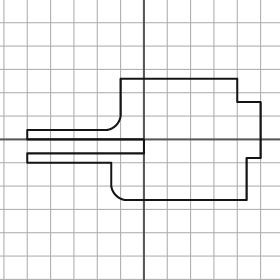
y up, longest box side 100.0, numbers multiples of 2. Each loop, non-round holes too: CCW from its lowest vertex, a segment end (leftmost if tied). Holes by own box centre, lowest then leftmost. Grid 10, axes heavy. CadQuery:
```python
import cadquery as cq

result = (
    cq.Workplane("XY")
    .moveTo(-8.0, -26.0)
    .lineTo(44.0, -26.0)
    .lineTo(44.0, -8.0)
    .lineTo(50.0, -8.0)
    .lineTo(50.0, 16.0)
    .lineTo(40.0, 16.0)
    .lineTo(40.0, 26.0)
    .lineTo(-10.0, 26.0)
    .lineTo(-10.0, 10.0)
    .threePointArc((-12.0, 6.0), (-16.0, 4.0))
    .lineTo(-50.0, 4.0)
    .lineTo(-50.0, 0.0)
    .lineTo(0.0, 0.0)
    .lineTo(0.0, -6.0)
    .lineTo(-50.0, -6.0)
    .lineTo(-50.0, -10.0)
    .lineTo(-14.0, -10.0)
    .lineTo(-14.0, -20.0)
    .threePointArc((-12.0, -24.0), (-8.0, -26.0))
    .close()
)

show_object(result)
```